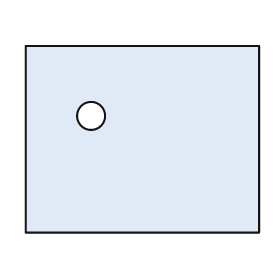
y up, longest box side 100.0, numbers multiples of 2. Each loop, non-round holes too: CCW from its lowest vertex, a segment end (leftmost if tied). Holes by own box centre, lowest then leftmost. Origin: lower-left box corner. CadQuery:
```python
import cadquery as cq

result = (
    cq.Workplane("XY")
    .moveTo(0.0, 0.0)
    .lineTo(100.0, 0.0)
    .lineTo(100.0, 80.0)
    .lineTo(0.0, 80.0)
    .close()
    .moveTo(28.0, 50.0)
    .circle(6.0)
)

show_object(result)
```